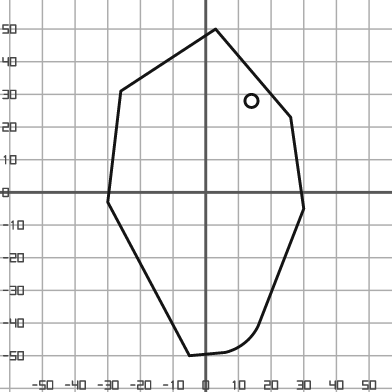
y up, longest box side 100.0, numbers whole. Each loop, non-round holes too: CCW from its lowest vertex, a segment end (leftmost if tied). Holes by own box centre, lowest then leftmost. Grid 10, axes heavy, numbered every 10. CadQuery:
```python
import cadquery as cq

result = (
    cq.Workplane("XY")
    .moveTo(-5.0, -50.0)
    .lineTo(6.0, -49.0)
    .threePointArc((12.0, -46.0), (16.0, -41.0))
    .lineTo(30.0, -5.0)
    .lineTo(26.0, 23.0)
    .lineTo(3.0, 50.0)
    .lineTo(-26.0, 31.0)
    .lineTo(-30.0, -3.0)
    .close()
    .moveTo(14.0, 28.0)
    .circle(2.0)
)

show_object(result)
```